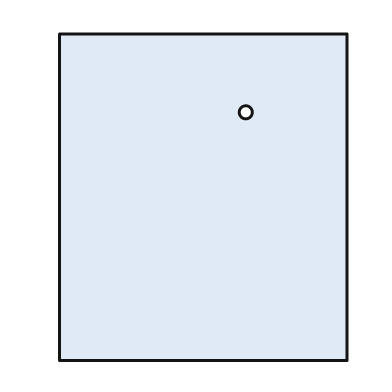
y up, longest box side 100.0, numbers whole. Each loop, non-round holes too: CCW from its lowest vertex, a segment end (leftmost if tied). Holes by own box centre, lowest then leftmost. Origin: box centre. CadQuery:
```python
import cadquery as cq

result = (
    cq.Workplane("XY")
    .moveTo(-44.0, -50.0)
    .lineTo(44.0, -50.0)
    .lineTo(44.0, 50.0)
    .lineTo(-44.0, 50.0)
    .close()
    .moveTo(13.0, 26.0)
    .circle(2.0)
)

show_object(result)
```